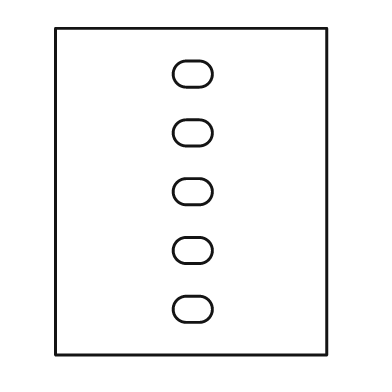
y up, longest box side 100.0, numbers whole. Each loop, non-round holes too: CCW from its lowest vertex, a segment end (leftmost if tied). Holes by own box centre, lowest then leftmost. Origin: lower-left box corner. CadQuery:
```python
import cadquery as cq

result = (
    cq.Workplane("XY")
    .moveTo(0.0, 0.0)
    .lineTo(83.0, 0.0)
    .lineTo(83.0, 100.0)
    .lineTo(0.0, 100.0)
    .close()
    .moveTo(40.0, 10.0)
    .lineTo(44.0, 10.0)
    .threePointArc((48.0, 14.0), (44.0, 18.0))
    .lineTo(40.0, 18.0)
    .threePointArc((36.0, 14.0), (40.0, 10.0))
    .close()
    .moveTo(40.0, 28.0)
    .lineTo(44.0, 28.0)
    .threePointArc((48.0, 32.0), (44.0, 36.0))
    .lineTo(40.0, 36.0)
    .threePointArc((36.0, 32.0), (40.0, 28.0))
    .close()
    .moveTo(40.0, 46.0)
    .lineTo(44.0, 46.0)
    .threePointArc((48.0, 50.0), (44.0, 54.0))
    .lineTo(40.0, 54.0)
    .threePointArc((36.0, 50.0), (40.0, 46.0))
    .close()
    .moveTo(40.0, 64.0)
    .lineTo(44.0, 64.0)
    .threePointArc((48.0, 68.0), (44.0, 72.0))
    .lineTo(40.0, 72.0)
    .threePointArc((36.0, 68.0), (40.0, 64.0))
    .close()
    .moveTo(40.0, 82.0)
    .lineTo(44.0, 82.0)
    .threePointArc((48.0, 86.0), (44.0, 90.0))
    .lineTo(40.0, 90.0)
    .threePointArc((36.0, 86.0), (40.0, 82.0))
    .close()
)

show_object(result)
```